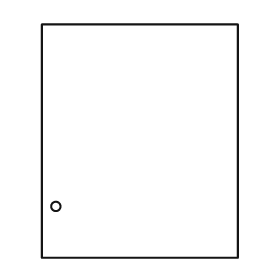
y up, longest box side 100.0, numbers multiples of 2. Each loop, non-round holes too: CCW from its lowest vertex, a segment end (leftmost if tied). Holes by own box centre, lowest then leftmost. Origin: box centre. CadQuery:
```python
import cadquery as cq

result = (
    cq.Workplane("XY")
    .moveTo(-42.0, -50.0)
    .lineTo(42.0, -50.0)
    .lineTo(42.0, 50.0)
    .lineTo(-42.0, 50.0)
    .close()
    .moveTo(-36.0, -28.0)
    .circle(2.0)
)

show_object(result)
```